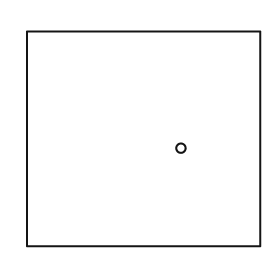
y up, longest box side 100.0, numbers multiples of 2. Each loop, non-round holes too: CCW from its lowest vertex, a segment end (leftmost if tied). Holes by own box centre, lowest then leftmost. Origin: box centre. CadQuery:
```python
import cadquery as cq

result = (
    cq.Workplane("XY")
    .moveTo(-50.0, -46.0)
    .lineTo(50.0, -46.0)
    .lineTo(50.0, 46.0)
    .lineTo(-50.0, 46.0)
    .close()
    .moveTo(16.0, -4.0)
    .circle(2.0)
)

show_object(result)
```